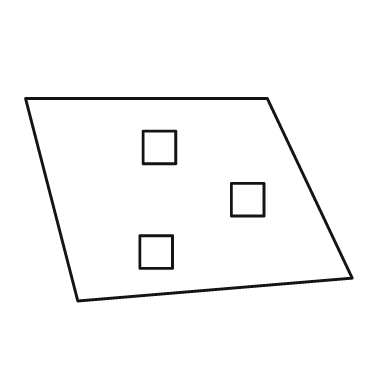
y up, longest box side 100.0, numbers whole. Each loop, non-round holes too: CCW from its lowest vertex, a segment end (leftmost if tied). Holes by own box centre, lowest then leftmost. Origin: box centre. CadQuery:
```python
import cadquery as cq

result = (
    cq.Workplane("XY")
    .moveTo(-34.0, -31.0)
    .lineTo(50.0, -24.0)
    .lineTo(24.0, 31.0)
    .lineTo(-50.0, 31.0)
    .close()
    .moveTo(-15.0, -21.0)
    .lineTo(-5.0, -21.0)
    .lineTo(-5.0, -11.0)
    .lineTo(-15.0, -11.0)
    .close()
    .moveTo(13.0, -5.0)
    .lineTo(23.0, -5.0)
    .lineTo(23.0, 5.0)
    .lineTo(13.0, 5.0)
    .close()
    .moveTo(-14.0, 11.0)
    .lineTo(-4.0, 11.0)
    .lineTo(-4.0, 21.0)
    .lineTo(-14.0, 21.0)
    .close()
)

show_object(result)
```